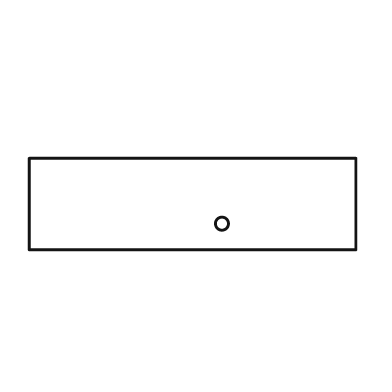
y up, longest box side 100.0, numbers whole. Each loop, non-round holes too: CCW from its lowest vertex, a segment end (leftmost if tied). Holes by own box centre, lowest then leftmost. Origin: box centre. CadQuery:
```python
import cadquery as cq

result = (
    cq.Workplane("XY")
    .moveTo(-50.0, -14.0)
    .lineTo(50.0, -14.0)
    .lineTo(50.0, 14.0)
    .lineTo(-50.0, 14.0)
    .close()
    .moveTo(9.0, -6.0)
    .circle(2.0)
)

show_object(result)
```